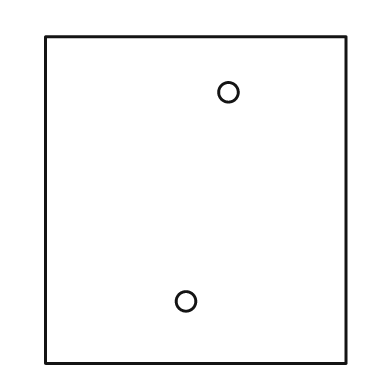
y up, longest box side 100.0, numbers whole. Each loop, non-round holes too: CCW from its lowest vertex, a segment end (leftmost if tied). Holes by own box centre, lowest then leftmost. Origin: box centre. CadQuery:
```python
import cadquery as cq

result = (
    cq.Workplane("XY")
    .moveTo(-46.0, -50.0)
    .lineTo(46.0, -50.0)
    .lineTo(46.0, 50.0)
    .lineTo(-46.0, 50.0)
    .close()
    .moveTo(-3.0, -31.0)
    .circle(3.0)
    .moveTo(10.0, 33.0)
    .circle(3.0)
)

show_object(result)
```